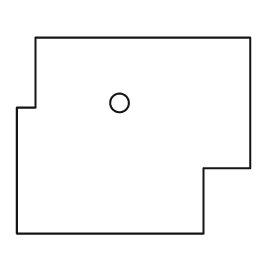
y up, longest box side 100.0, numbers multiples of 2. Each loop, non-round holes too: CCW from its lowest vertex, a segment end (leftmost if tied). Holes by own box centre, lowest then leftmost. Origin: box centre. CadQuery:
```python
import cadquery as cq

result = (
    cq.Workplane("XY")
    .moveTo(-50.0, -42.0)
    .lineTo(30.0, -42.0)
    .lineTo(30.0, -14.0)
    .lineTo(50.0, -14.0)
    .lineTo(50.0, 42.0)
    .lineTo(-42.0, 42.0)
    .lineTo(-42.0, 12.0)
    .lineTo(-50.0, 12.0)
    .close()
    .moveTo(-6.0, 14.0)
    .circle(4.0)
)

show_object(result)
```